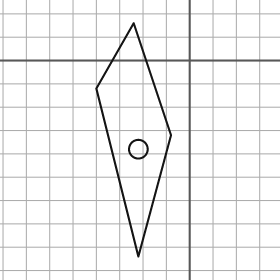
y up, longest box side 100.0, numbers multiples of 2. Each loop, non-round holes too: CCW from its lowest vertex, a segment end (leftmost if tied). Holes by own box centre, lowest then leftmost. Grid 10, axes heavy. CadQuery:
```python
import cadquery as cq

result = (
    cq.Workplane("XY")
    .moveTo(-22.0, -84.0)
    .lineTo(-8.0, -32.0)
    .lineTo(-24.0, 16.0)
    .lineTo(-40.0, -12.0)
    .close()
    .moveTo(-22.0, -38.0)
    .circle(4.0)
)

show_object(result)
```